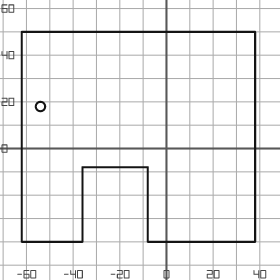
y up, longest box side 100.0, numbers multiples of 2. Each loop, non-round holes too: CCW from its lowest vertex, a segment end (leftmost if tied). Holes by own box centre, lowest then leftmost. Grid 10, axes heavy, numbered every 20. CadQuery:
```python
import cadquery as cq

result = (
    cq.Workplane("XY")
    .moveTo(-62.0, -40.0)
    .lineTo(-36.0, -40.0)
    .lineTo(-36.0, -8.0)
    .lineTo(-8.0, -8.0)
    .lineTo(-8.0, -40.0)
    .lineTo(38.0, -40.0)
    .lineTo(38.0, 50.0)
    .lineTo(-62.0, 50.0)
    .close()
    .moveTo(-54.0, 18.0)
    .circle(2.0)
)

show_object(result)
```